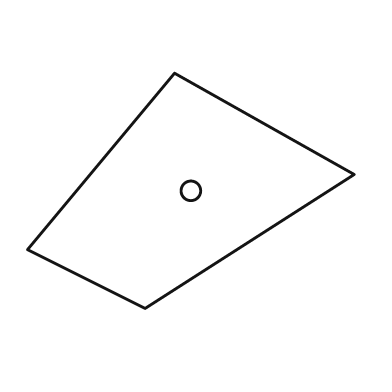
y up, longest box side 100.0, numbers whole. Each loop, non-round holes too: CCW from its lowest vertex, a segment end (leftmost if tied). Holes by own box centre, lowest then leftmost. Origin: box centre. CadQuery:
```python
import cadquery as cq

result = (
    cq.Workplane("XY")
    .moveTo(-14.0, -36.0)
    .lineTo(50.0, 5.0)
    .lineTo(-5.0, 36.0)
    .lineTo(-50.0, -18.0)
    .close()
    .moveTo(0.0, 0.0)
    .circle(3.0)
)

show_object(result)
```